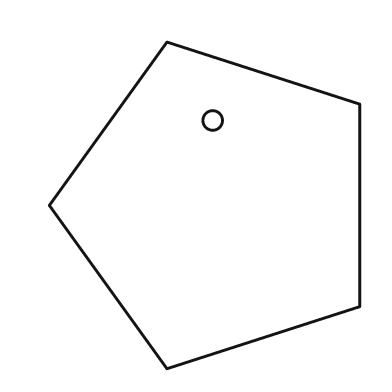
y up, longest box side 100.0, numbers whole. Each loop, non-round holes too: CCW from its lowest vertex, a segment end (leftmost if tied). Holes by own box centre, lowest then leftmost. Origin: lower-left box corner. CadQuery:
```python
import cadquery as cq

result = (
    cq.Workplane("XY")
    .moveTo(36.0, 0.0)
    .lineTo(95.0, 19.0)
    .lineTo(95.0, 81.0)
    .lineTo(36.0, 100.0)
    .lineTo(0.0, 50.0)
    .close()
    .moveTo(50.0, 76.0)
    .circle(3.0)
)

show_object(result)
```